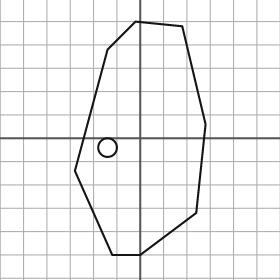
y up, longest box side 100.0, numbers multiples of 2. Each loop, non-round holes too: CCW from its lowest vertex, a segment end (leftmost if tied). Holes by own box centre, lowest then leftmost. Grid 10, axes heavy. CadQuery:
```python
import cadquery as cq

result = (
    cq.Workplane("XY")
    .moveTo(-12.0, -50.0)
    .lineTo(0.0, -50.0)
    .lineTo(24.0, -32.0)
    .lineTo(28.0, 6.0)
    .lineTo(18.0, 48.0)
    .lineTo(-2.0, 50.0)
    .lineTo(-14.0, 38.0)
    .lineTo(-28.0, -14.0)
    .close()
    .moveTo(-14.0, -4.0)
    .circle(4.0)
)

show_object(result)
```